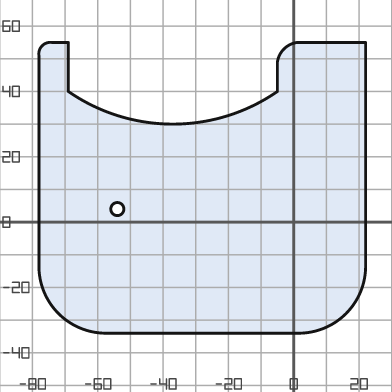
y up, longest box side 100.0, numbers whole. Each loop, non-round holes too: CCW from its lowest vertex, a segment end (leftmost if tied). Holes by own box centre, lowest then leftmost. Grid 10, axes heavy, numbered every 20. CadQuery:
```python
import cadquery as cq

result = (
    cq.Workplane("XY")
    .moveTo(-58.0, -34.0)
    .lineTo(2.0, -34.0)
    .threePointArc((16.0, -28.0), (22.0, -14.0))
    .lineTo(22.0, 55.0)
    .lineTo(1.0, 55.0)
    .threePointArc((-3.0, 53.0), (-5.0, 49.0))
    .lineTo(-5.0, 40.0)
    .threePointArc((-37.0, 30.0), (-69.0, 40.0))
    .lineTo(-69.0, 55.0)
    .lineTo(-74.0, 55.0)
    .threePointArc((-77.0, 54.0), (-78.0, 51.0))
    .lineTo(-78.0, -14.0)
    .threePointArc((-72.0, -28.0), (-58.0, -34.0))
    .close()
    .moveTo(-54.0, 4.0)
    .circle(2.0)
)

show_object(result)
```